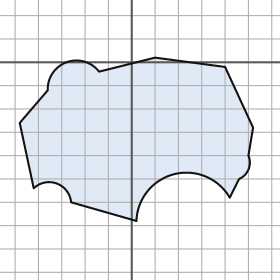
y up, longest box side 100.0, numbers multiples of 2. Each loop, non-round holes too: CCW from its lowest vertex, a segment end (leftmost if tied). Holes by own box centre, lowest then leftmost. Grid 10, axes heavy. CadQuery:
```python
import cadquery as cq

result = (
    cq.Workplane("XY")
    .moveTo(2.0, -68.0)
    .threePointArc((18.0, -48.0), (42.0, -58.0))
    .lineTo(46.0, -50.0)
    .threePointArc((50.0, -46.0), (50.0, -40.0))
    .lineTo(52.0, -28.0)
    .lineTo(40.0, -2.0)
    .lineTo(10.0, 2.0)
    .lineTo(-14.0, -4.0)
    .threePointArc((-28.0, 0.0), (-36.0, -12.0))
    .lineTo(-48.0, -26.0)
    .lineTo(-42.0, -54.0)
    .threePointArc((-32.0, -52.0), (-26.0, -60.0))
    .close()
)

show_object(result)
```